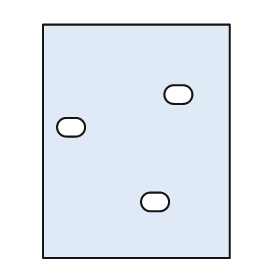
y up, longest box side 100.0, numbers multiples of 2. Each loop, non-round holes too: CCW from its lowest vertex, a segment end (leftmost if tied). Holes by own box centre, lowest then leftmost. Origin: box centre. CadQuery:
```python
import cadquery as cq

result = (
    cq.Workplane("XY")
    .moveTo(-40.0, -50.0)
    .lineTo(40.0, -50.0)
    .lineTo(40.0, 50.0)
    .lineTo(-40.0, 50.0)
    .close()
    .moveTo(6.0, -30.0)
    .lineTo(10.0, -30.0)
    .threePointArc((14.0, -26.0), (10.0, -22.0))
    .lineTo(6.0, -22.0)
    .threePointArc((2.0, -26.0), (6.0, -30.0))
    .close()
    .moveTo(-30.0, 2.0)
    .lineTo(-26.0, 2.0)
    .threePointArc((-22.0, 6.0), (-26.0, 10.0))
    .lineTo(-30.0, 10.0)
    .threePointArc((-34.0, 6.0), (-30.0, 2.0))
    .close()
    .moveTo(16.0, 16.0)
    .lineTo(20.0, 16.0)
    .threePointArc((24.0, 20.0), (20.0, 24.0))
    .lineTo(16.0, 24.0)
    .threePointArc((12.0, 20.0), (16.0, 16.0))
    .close()
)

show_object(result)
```